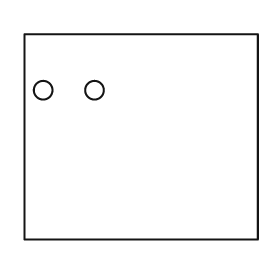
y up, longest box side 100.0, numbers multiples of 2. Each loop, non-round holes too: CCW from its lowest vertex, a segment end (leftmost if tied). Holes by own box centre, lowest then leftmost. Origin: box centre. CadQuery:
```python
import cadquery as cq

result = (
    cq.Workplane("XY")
    .moveTo(-50.0, -44.0)
    .lineTo(50.0, -44.0)
    .lineTo(50.0, 44.0)
    .lineTo(-50.0, 44.0)
    .close()
    .moveTo(-42.0, 20.0)
    .circle(4.0)
    .moveTo(-20.0, 20.0)
    .circle(4.0)
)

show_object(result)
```